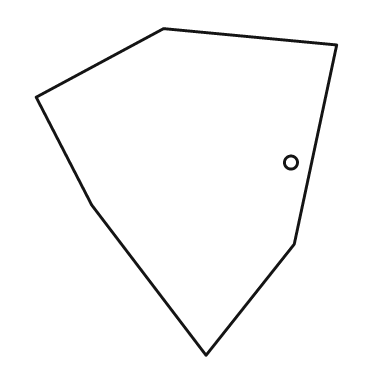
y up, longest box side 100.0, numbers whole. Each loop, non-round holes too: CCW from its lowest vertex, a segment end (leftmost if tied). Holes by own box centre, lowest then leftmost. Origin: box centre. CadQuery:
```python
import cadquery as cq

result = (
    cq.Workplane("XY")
    .moveTo(6.0, -50.0)
    .lineTo(33.0, -16.0)
    .lineTo(46.0, 45.0)
    .lineTo(-7.0, 50.0)
    .lineTo(-46.0, 29.0)
    .lineTo(-29.0, -4.0)
    .close()
    .moveTo(32.0, 9.0)
    .circle(2.0)
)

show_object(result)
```